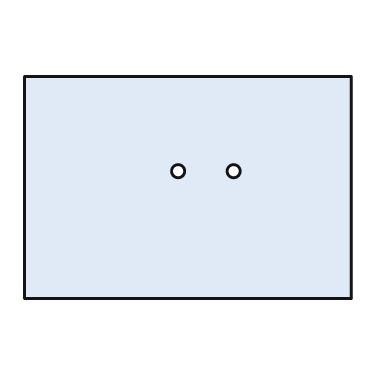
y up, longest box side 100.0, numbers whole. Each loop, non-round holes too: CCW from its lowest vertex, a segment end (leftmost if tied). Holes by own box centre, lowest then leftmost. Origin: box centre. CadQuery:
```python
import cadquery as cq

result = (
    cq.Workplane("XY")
    .moveTo(-50.0, -34.0)
    .lineTo(50.0, -34.0)
    .lineTo(50.0, 34.0)
    .lineTo(-50.0, 34.0)
    .close()
    .moveTo(-3.0, 5.0)
    .circle(2.0)
    .moveTo(14.0, 5.0)
    .circle(2.0)
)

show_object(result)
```